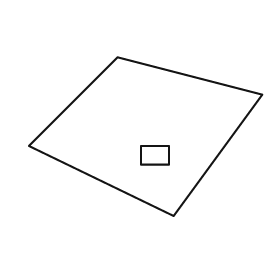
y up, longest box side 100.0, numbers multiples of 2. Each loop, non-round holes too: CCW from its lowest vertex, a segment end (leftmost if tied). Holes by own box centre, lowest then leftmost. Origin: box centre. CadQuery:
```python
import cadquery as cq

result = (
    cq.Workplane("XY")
    .moveTo(12.0, -34.0)
    .lineTo(50.0, 18.0)
    .lineTo(-12.0, 34.0)
    .lineTo(-50.0, -4.0)
    .close()
    .moveTo(-2.0, -12.0)
    .lineTo(10.0, -12.0)
    .lineTo(10.0, -4.0)
    .lineTo(-2.0, -4.0)
    .close()
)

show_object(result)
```